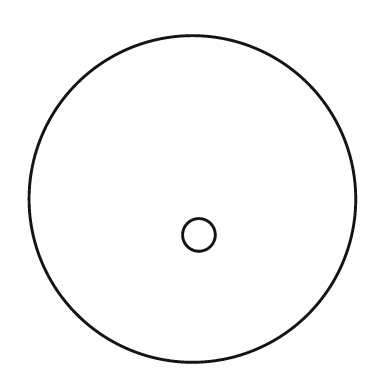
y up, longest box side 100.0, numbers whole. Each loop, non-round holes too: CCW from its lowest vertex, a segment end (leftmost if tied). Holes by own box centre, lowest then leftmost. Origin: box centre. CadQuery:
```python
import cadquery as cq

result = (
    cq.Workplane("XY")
    .moveTo(0.0, 0.0)
    .circle(50.0)
    .moveTo(2.0, -11.0)
    .circle(5.0)
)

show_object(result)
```